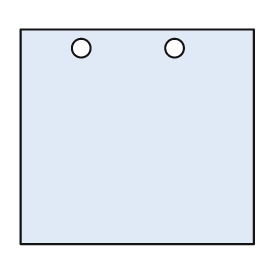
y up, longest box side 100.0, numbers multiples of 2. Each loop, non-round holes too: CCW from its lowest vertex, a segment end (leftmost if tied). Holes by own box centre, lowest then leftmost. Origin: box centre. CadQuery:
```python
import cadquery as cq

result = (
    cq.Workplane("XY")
    .moveTo(-50.0, -46.0)
    .lineTo(50.0, -46.0)
    .lineTo(50.0, 46.0)
    .lineTo(-50.0, 46.0)
    .close()
    .moveTo(-24.0, 38.0)
    .circle(4.0)
    .moveTo(16.0, 38.0)
    .circle(4.0)
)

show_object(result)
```